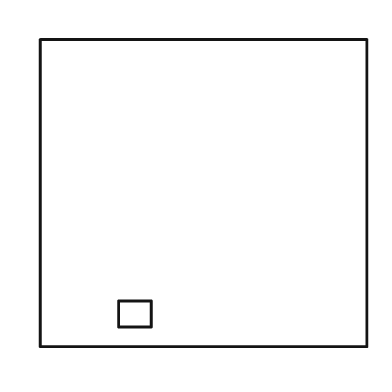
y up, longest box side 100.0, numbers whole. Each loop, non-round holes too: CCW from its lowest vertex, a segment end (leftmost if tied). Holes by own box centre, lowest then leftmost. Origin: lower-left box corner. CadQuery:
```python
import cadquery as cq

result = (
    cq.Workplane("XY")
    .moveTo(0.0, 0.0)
    .lineTo(100.0, 0.0)
    .lineTo(100.0, 94.0)
    .lineTo(0.0, 94.0)
    .close()
    .moveTo(24.0, 6.0)
    .lineTo(34.0, 6.0)
    .lineTo(34.0, 14.0)
    .lineTo(24.0, 14.0)
    .close()
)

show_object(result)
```